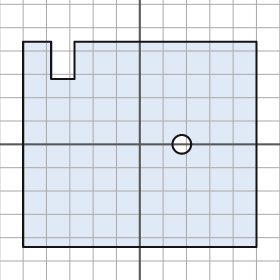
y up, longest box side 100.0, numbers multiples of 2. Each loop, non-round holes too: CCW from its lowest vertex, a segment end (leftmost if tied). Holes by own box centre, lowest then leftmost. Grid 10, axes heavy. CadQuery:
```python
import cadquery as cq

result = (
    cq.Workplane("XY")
    .moveTo(-50.0, -44.0)
    .lineTo(50.0, -44.0)
    .lineTo(50.0, 44.0)
    .lineTo(-28.0, 44.0)
    .lineTo(-28.0, 28.0)
    .lineTo(-38.0, 28.0)
    .lineTo(-38.0, 44.0)
    .lineTo(-50.0, 44.0)
    .close()
    .moveTo(18.0, 0.0)
    .circle(4.0)
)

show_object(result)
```